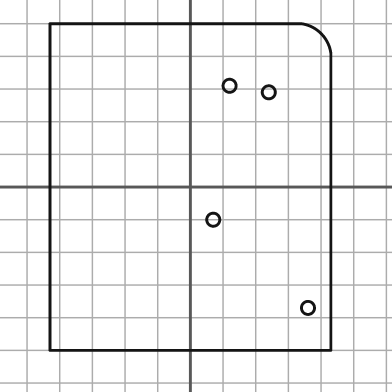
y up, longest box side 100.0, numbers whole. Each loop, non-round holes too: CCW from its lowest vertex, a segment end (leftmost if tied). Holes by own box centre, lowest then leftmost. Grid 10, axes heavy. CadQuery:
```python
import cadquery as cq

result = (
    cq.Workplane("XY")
    .moveTo(-43.0, -50.0)
    .lineTo(43.0, -50.0)
    .lineTo(43.0, 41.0)
    .threePointArc((40.0, 47.0), (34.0, 50.0))
    .lineTo(-43.0, 50.0)
    .close()
    .moveTo(36.0, -37.0)
    .circle(2.0)
    .moveTo(7.0, -10.0)
    .circle(2.0)
    .moveTo(24.0, 29.0)
    .circle(2.0)
    .moveTo(12.0, 31.0)
    .circle(2.0)
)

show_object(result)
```